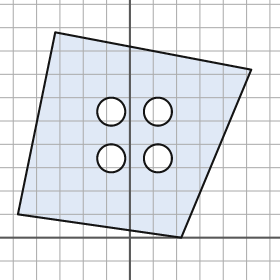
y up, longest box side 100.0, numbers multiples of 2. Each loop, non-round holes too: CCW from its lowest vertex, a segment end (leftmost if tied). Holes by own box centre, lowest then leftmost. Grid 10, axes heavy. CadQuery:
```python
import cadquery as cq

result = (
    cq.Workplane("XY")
    .moveTo(22.0, 0.0)
    .lineTo(52.0, 72.0)
    .lineTo(-32.0, 88.0)
    .lineTo(-48.0, 10.0)
    .close()
    .moveTo(-8.0, 34.0)
    .circle(6.0)
    .moveTo(12.0, 34.0)
    .circle(6.0)
    .moveTo(-8.0, 54.0)
    .circle(6.0)
    .moveTo(12.0, 54.0)
    .circle(6.0)
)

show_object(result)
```